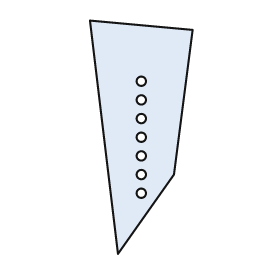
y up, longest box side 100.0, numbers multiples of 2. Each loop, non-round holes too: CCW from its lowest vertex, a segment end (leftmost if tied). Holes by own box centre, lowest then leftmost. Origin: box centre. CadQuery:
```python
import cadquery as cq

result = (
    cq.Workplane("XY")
    .moveTo(-10.0, -50.0)
    .lineTo(14.0, -16.0)
    .lineTo(22.0, 46.0)
    .lineTo(-22.0, 50.0)
    .close()
    .moveTo(0.0, -24.0)
    .circle(2.0)
    .moveTo(0.0, -16.0)
    .circle(2.0)
    .moveTo(0.0, -8.0)
    .circle(2.0)
    .moveTo(0.0, 0.0)
    .circle(2.0)
    .moveTo(0.0, 8.0)
    .circle(2.0)
    .moveTo(0.0, 16.0)
    .circle(2.0)
    .moveTo(0.0, 24.0)
    .circle(2.0)
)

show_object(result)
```